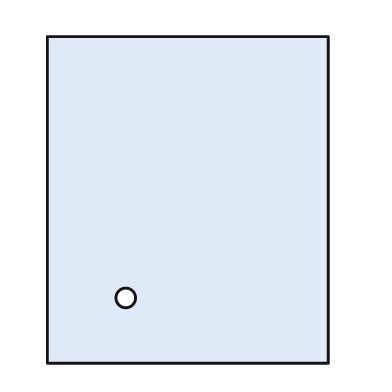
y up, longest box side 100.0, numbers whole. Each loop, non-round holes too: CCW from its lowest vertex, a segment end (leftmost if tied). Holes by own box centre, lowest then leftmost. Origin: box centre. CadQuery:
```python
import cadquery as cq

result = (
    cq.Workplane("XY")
    .moveTo(-43.0, -50.0)
    .lineTo(43.0, -50.0)
    .lineTo(43.0, 50.0)
    .lineTo(-43.0, 50.0)
    .close()
    .moveTo(-19.0, -30.0)
    .circle(3.0)
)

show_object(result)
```